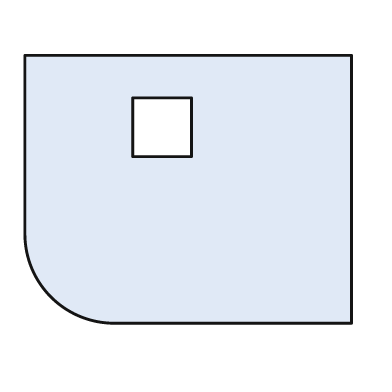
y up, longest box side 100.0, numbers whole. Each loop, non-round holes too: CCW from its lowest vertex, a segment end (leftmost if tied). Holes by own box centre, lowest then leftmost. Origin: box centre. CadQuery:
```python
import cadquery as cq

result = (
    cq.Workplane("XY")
    .moveTo(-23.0, -41.0)
    .lineTo(50.0, -41.0)
    .lineTo(50.0, 41.0)
    .lineTo(-50.0, 41.0)
    .lineTo(-50.0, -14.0)
    .threePointArc((-42.0, -33.0), (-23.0, -41.0))
    .close()
    .moveTo(-17.0, 10.0)
    .lineTo(1.0, 10.0)
    .lineTo(1.0, 28.0)
    .lineTo(-17.0, 28.0)
    .close()
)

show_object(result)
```